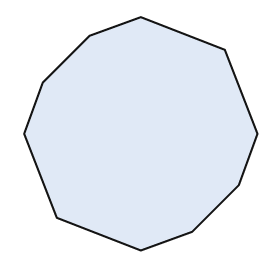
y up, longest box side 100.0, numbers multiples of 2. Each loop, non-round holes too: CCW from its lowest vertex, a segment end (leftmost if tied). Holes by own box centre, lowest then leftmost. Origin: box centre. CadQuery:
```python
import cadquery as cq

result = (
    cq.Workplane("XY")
    .moveTo(0.0, -50.0)
    .lineTo(22.0, -42.0)
    .lineTo(42.0, -22.0)
    .lineTo(50.0, 0.0)
    .lineTo(36.0, 36.0)
    .lineTo(0.0, 50.0)
    .lineTo(-22.0, 42.0)
    .lineTo(-42.0, 22.0)
    .lineTo(-50.0, 0.0)
    .lineTo(-36.0, -36.0)
    .close()
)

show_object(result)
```